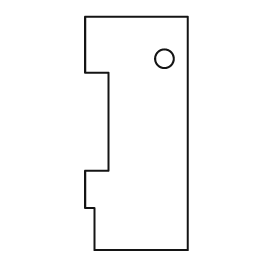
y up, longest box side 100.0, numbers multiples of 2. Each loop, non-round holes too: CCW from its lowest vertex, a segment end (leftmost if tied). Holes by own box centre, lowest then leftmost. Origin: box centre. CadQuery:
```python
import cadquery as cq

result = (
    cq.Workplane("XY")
    .moveTo(-18.0, -50.0)
    .lineTo(22.0, -50.0)
    .lineTo(22.0, 50.0)
    .lineTo(-22.0, 50.0)
    .lineTo(-22.0, 26.0)
    .lineTo(-12.0, 26.0)
    .lineTo(-12.0, -16.0)
    .lineTo(-22.0, -16.0)
    .lineTo(-22.0, -32.0)
    .lineTo(-18.0, -32.0)
    .close()
    .moveTo(12.0, 32.0)
    .circle(4.0)
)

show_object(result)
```